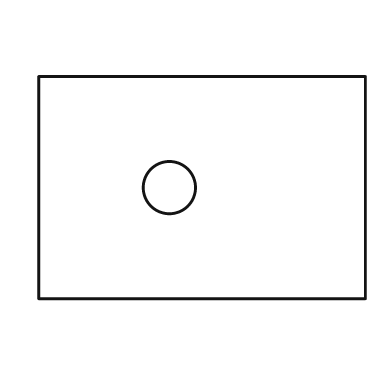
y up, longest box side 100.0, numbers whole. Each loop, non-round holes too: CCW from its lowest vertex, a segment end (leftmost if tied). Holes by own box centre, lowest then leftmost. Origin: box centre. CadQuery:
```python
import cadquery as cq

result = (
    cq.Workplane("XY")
    .moveTo(-50.0, -34.0)
    .lineTo(50.0, -34.0)
    .lineTo(50.0, 34.0)
    .lineTo(-50.0, 34.0)
    .close()
    .moveTo(-10.0, 0.0)
    .circle(8.0)
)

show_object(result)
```